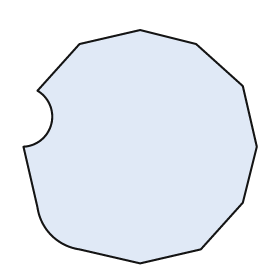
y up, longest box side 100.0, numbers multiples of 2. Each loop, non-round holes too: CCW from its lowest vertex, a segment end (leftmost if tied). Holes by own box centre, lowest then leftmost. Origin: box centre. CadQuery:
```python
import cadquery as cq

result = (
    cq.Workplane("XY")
    .moveTo(0.0, -50.0)
    .lineTo(26.0, -44.0)
    .lineTo(44.0, -24.0)
    .lineTo(50.0, 0.0)
    .lineTo(44.0, 26.0)
    .lineTo(24.0, 44.0)
    .lineTo(0.0, 50.0)
    .lineTo(-26.0, 44.0)
    .lineTo(-44.0, 24.0)
    .threePointArc((-38.0, 10.0), (-50.0, 0.0))
    .lineTo(-44.0, -26.0)
    .threePointArc((-38.0, -38.0), (-26.0, -44.0))
    .close()
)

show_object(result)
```